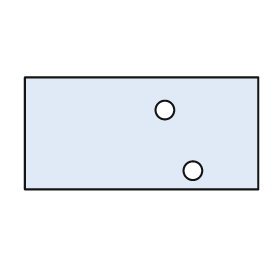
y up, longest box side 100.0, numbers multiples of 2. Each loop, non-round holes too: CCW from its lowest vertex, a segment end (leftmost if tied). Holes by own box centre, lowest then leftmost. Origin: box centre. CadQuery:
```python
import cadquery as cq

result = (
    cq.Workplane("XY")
    .moveTo(-50.0, -24.0)
    .lineTo(50.0, -24.0)
    .lineTo(50.0, 24.0)
    .lineTo(-50.0, 24.0)
    .close()
    .moveTo(22.0, -16.0)
    .circle(4.0)
    .moveTo(10.0, 10.0)
    .circle(4.0)
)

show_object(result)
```